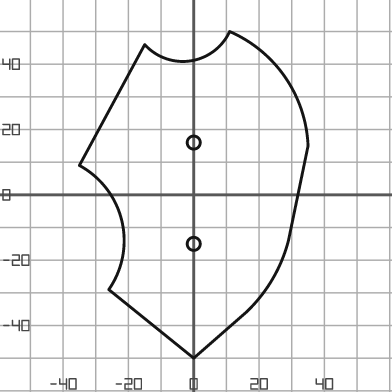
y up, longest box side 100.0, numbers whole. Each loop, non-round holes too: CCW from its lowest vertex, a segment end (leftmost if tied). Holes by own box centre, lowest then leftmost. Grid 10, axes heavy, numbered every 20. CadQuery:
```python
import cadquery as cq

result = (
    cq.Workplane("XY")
    .moveTo(0.0, -50.0)
    .lineTo(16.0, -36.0)
    .threePointArc((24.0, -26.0), (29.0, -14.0))
    .lineTo(35.0, 15.0)
    .threePointArc((28.0, 36.0), (11.0, 50.0))
    .threePointArc((-1.0, 41.0), (-15.0, 46.0))
    .lineTo(-35.0, 9.0)
    .threePointArc((-22.0, -8.0), (-26.0, -29.0))
    .close()
    .moveTo(0.0, -15.0)
    .circle(2.0)
    .moveTo(0.0, 16.0)
    .circle(2.0)
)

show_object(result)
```